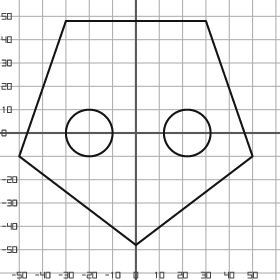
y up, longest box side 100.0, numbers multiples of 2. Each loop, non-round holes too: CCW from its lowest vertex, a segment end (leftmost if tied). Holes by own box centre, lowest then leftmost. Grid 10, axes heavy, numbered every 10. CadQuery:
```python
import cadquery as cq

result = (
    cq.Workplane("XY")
    .moveTo(0.0, -48.0)
    .lineTo(50.0, -10.0)
    .lineTo(30.0, 48.0)
    .lineTo(-30.0, 48.0)
    .lineTo(-50.0, -10.0)
    .close()
    .moveTo(-20.0, 0.0)
    .circle(10.0)
    .moveTo(22.0, 0.0)
    .circle(10.0)
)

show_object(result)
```